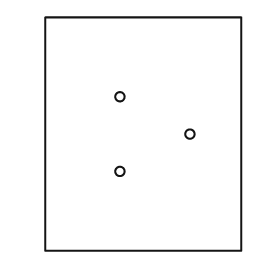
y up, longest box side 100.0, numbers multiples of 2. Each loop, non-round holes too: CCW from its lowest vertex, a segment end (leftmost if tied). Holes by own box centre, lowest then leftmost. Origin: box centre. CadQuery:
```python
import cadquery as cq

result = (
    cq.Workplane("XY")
    .moveTo(-42.0, -50.0)
    .lineTo(42.0, -50.0)
    .lineTo(42.0, 50.0)
    .lineTo(-42.0, 50.0)
    .close()
    .moveTo(-10.0, -16.0)
    .circle(2.0)
    .moveTo(20.0, 0.0)
    .circle(2.0)
    .moveTo(-10.0, 16.0)
    .circle(2.0)
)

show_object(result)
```